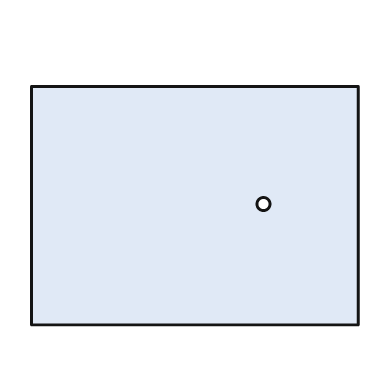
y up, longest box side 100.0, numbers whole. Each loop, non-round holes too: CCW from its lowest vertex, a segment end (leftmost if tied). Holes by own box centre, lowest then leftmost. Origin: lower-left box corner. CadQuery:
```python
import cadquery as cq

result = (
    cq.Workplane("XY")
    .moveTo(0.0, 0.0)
    .lineTo(100.0, 0.0)
    .lineTo(100.0, 73.0)
    .lineTo(0.0, 73.0)
    .close()
    .moveTo(71.0, 37.0)
    .circle(2.0)
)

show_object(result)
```